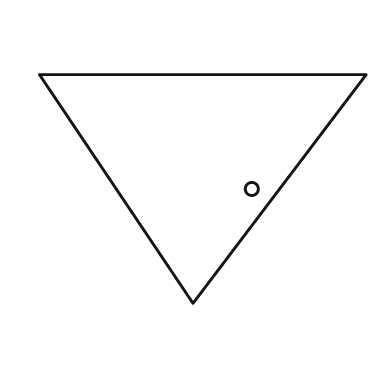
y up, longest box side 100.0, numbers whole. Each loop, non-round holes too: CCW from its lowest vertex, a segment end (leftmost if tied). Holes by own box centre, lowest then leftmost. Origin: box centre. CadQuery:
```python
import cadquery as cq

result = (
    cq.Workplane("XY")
    .moveTo(-3.0, -35.0)
    .lineTo(50.0, 35.0)
    .lineTo(-50.0, 35.0)
    .close()
    .moveTo(15.0, 0.0)
    .circle(2.0)
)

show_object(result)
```